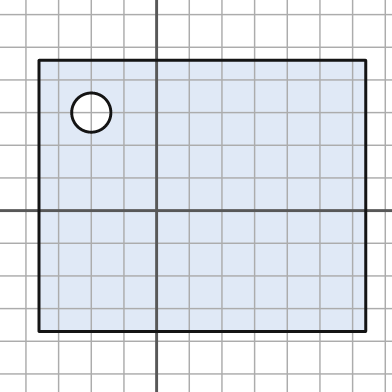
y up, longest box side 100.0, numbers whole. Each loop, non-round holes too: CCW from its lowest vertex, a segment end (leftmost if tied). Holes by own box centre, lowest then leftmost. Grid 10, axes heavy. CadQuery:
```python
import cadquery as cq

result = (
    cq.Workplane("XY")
    .moveTo(-36.0, -37.0)
    .lineTo(64.0, -37.0)
    .lineTo(64.0, 46.0)
    .lineTo(-36.0, 46.0)
    .close()
    .moveTo(-20.0, 30.0)
    .circle(6.0)
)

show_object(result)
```